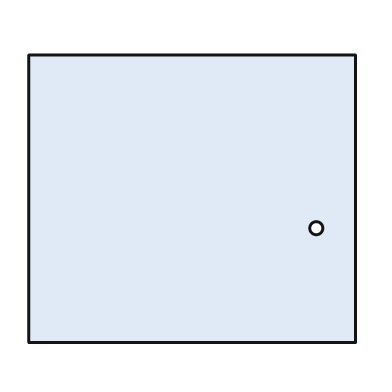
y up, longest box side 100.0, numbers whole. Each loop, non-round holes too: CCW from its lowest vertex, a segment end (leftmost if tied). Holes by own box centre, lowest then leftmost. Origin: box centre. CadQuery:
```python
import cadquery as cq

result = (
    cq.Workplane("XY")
    .moveTo(-50.0, -44.0)
    .lineTo(50.0, -44.0)
    .lineTo(50.0, 44.0)
    .lineTo(-50.0, 44.0)
    .close()
    .moveTo(38.0, -9.0)
    .circle(2.0)
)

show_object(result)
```